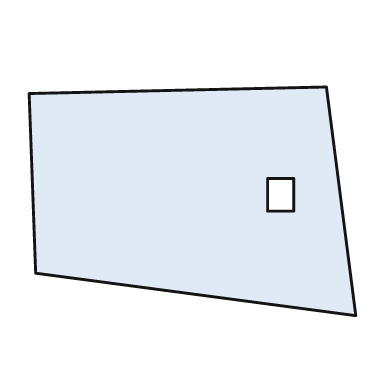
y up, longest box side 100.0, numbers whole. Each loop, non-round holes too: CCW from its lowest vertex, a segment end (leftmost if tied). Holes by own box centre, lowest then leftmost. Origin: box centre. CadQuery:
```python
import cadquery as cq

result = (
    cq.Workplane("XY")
    .moveTo(50.0, -35.0)
    .lineTo(41.0, 35.0)
    .lineTo(-50.0, 33.0)
    .lineTo(-48.0, -22.0)
    .close()
    .moveTo(23.0, -3.0)
    .lineTo(31.0, -3.0)
    .lineTo(31.0, 7.0)
    .lineTo(23.0, 7.0)
    .close()
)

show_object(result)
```